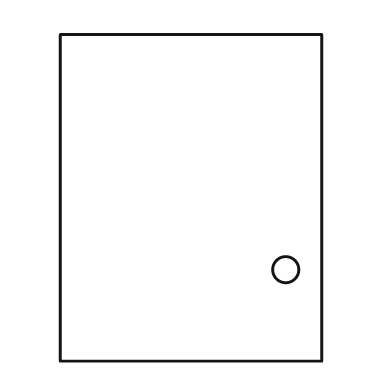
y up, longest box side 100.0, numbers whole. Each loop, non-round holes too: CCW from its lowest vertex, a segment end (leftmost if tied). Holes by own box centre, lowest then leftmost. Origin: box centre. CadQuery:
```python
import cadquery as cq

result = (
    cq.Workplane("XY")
    .moveTo(-40.0, -50.0)
    .lineTo(40.0, -50.0)
    .lineTo(40.0, 50.0)
    .lineTo(-40.0, 50.0)
    .close()
    .moveTo(29.0, -22.0)
    .circle(4.0)
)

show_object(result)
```